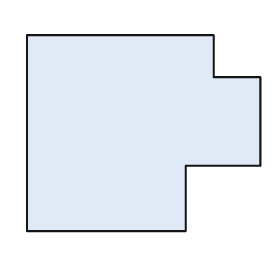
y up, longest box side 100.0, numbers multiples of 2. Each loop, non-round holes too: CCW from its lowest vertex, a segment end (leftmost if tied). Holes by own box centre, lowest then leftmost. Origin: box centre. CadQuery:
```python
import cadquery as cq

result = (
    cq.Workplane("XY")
    .moveTo(-50.0, -42.0)
    .lineTo(18.0, -42.0)
    .lineTo(18.0, -14.0)
    .lineTo(50.0, -14.0)
    .lineTo(50.0, 24.0)
    .lineTo(30.0, 24.0)
    .lineTo(30.0, 42.0)
    .lineTo(-50.0, 42.0)
    .close()
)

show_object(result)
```